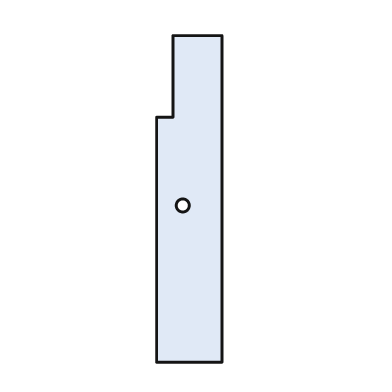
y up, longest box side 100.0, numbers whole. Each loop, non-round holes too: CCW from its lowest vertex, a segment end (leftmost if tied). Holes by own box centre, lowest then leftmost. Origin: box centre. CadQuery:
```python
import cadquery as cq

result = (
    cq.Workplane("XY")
    .moveTo(-10.0, -50.0)
    .lineTo(10.0, -50.0)
    .lineTo(10.0, 50.0)
    .lineTo(-5.0, 50.0)
    .lineTo(-5.0, 25.0)
    .lineTo(-10.0, 25.0)
    .close()
    .moveTo(-2.0, -2.0)
    .circle(2.0)
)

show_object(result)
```